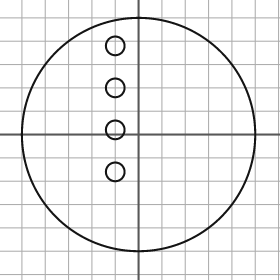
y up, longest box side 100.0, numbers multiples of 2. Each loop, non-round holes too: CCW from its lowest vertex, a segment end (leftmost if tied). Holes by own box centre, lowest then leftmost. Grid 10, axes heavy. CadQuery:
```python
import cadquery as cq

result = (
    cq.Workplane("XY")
    .moveTo(0.0, 0.0)
    .circle(50.0)
    .moveTo(-10.0, -16.0)
    .circle(4.0)
    .moveTo(-10.0, 2.0)
    .circle(4.0)
    .moveTo(-10.0, 20.0)
    .circle(4.0)
    .moveTo(-10.0, 38.0)
    .circle(4.0)
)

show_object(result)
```